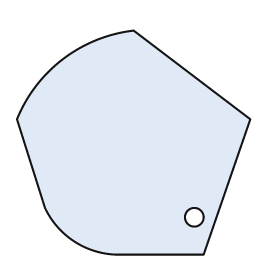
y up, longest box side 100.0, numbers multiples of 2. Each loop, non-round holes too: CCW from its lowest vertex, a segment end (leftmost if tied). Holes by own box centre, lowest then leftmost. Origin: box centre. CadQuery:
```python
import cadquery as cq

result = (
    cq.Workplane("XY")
    .moveTo(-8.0, -48.0)
    .lineTo(30.0, -48.0)
    .lineTo(50.0, 10.0)
    .lineTo(0.0, 48.0)
    .threePointArc((-30.0, 36.0), (-50.0, 10.0))
    .lineTo(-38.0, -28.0)
    .threePointArc((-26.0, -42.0), (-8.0, -48.0))
    .close()
    .moveTo(26.0, -32.0)
    .circle(4.0)
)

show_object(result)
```